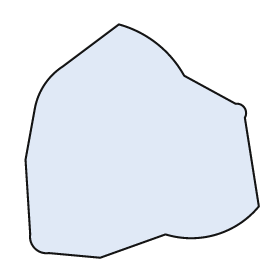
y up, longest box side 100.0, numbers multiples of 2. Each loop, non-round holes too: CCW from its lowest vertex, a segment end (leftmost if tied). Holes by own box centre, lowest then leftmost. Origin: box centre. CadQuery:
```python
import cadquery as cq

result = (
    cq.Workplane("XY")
    .moveTo(-18.0, -50.0)
    .lineTo(10.0, -40.0)
    .threePointArc((32.0, -40.0), (50.0, -28.0))
    .lineTo(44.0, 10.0)
    .threePointArc((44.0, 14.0), (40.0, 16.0))
    .lineTo(18.0, 28.0)
    .threePointArc((6.0, 42.0), (-10.0, 50.0))
    .lineTo(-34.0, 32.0)
    .threePointArc((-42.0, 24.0), (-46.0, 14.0))
    .lineTo(-50.0, -8.0)
    .lineTo(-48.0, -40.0)
    .threePointArc((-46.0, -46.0), (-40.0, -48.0))
    .close()
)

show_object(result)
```